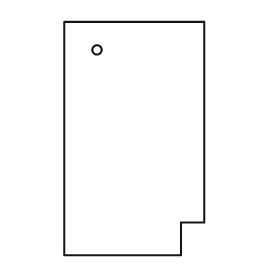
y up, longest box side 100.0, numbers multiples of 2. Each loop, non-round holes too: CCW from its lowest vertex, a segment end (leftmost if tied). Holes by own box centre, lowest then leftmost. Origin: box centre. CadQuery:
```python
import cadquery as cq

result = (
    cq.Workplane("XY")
    .moveTo(-30.0, -50.0)
    .lineTo(20.0, -50.0)
    .lineTo(20.0, -36.0)
    .lineTo(30.0, -36.0)
    .lineTo(30.0, 50.0)
    .lineTo(-30.0, 50.0)
    .close()
    .moveTo(-16.0, 38.0)
    .circle(2.0)
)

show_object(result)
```